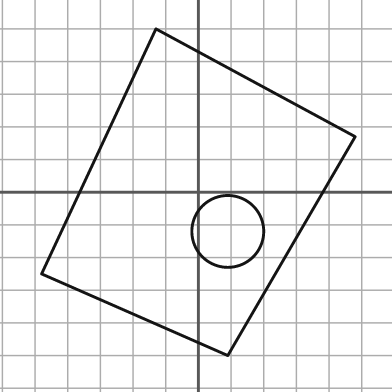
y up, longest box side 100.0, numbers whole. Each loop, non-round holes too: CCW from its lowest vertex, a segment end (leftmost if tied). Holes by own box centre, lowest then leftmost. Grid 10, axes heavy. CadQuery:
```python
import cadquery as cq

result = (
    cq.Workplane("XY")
    .moveTo(9.0, -50.0)
    .lineTo(48.0, 17.0)
    .lineTo(-13.0, 50.0)
    .lineTo(-48.0, -25.0)
    .close()
    .moveTo(9.0, -12.0)
    .circle(11.0)
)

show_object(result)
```